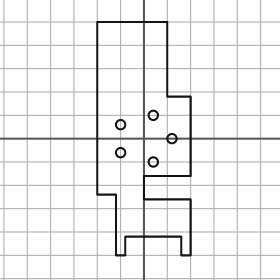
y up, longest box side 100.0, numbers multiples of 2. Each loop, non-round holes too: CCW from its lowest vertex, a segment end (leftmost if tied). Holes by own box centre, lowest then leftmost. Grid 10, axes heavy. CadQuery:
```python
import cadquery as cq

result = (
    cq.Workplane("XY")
    .moveTo(-12.0, -50.0)
    .lineTo(-8.0, -50.0)
    .lineTo(-8.0, -42.0)
    .lineTo(16.0, -42.0)
    .lineTo(16.0, -50.0)
    .lineTo(20.0, -50.0)
    .lineTo(20.0, -26.0)
    .lineTo(0.0, -26.0)
    .lineTo(0.0, -16.0)
    .lineTo(20.0, -16.0)
    .lineTo(20.0, 18.0)
    .lineTo(10.0, 18.0)
    .lineTo(10.0, 50.0)
    .lineTo(-20.0, 50.0)
    .lineTo(-20.0, -24.0)
    .lineTo(-12.0, -24.0)
    .close()
    .moveTo(4.0, -10.0)
    .circle(2.0)
    .moveTo(-10.0, -6.0)
    .circle(2.0)
    .moveTo(12.0, 0.0)
    .circle(2.0)
    .moveTo(-10.0, 6.0)
    .circle(2.0)
    .moveTo(4.0, 10.0)
    .circle(2.0)
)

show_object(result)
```